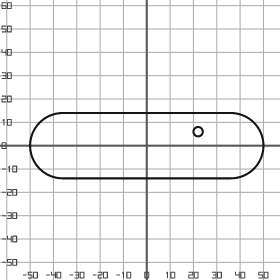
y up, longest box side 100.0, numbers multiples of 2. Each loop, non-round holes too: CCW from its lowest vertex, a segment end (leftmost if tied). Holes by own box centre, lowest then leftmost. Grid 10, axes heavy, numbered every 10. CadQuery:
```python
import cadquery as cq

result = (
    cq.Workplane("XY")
    .moveTo(-36.0, -14.0)
    .lineTo(36.0, -14.0)
    .threePointArc((50.0, 0.0), (36.0, 14.0))
    .lineTo(-36.0, 14.0)
    .threePointArc((-50.0, 0.0), (-36.0, -14.0))
    .close()
    .moveTo(22.0, 6.0)
    .circle(2.0)
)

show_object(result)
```